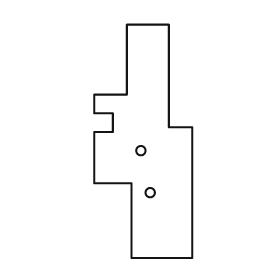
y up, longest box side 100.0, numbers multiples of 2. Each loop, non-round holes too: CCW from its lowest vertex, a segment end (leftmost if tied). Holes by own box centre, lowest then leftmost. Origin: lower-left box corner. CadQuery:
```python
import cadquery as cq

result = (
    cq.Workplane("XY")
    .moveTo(16.0, 0.0)
    .lineTo(42.0, 0.0)
    .lineTo(42.0, 56.0)
    .lineTo(32.0, 56.0)
    .lineTo(32.0, 100.0)
    .lineTo(14.0, 100.0)
    .lineTo(14.0, 70.0)
    .lineTo(0.0, 70.0)
    .lineTo(0.0, 62.0)
    .lineTo(8.0, 62.0)
    .lineTo(8.0, 54.0)
    .lineTo(0.0, 54.0)
    .lineTo(0.0, 32.0)
    .lineTo(16.0, 32.0)
    .close()
    .moveTo(24.0, 28.0)
    .circle(2.0)
    .moveTo(20.0, 46.0)
    .circle(2.0)
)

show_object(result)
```